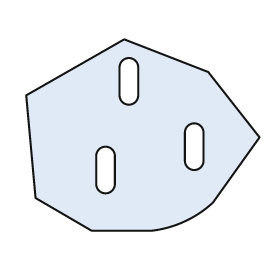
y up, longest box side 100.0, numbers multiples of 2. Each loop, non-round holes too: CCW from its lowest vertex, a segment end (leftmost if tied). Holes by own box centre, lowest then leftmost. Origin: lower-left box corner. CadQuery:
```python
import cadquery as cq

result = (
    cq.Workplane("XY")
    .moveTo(28.0, 0.0)
    .lineTo(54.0, 0.0)
    .threePointArc((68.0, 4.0), (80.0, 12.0))
    .lineTo(100.0, 40.0)
    .lineTo(78.0, 68.0)
    .lineTo(42.0, 82.0)
    .lineTo(0.0, 58.0)
    .lineTo(4.0, 14.0)
    .close()
    .moveTo(30.0, 20.0)
    .threePointArc((34.0, 16.0), (38.0, 20.0))
    .lineTo(38.0, 32.0)
    .threePointArc((34.0, 36.0), (30.0, 32.0))
    .close()
    .moveTo(68.0, 30.0)
    .threePointArc((72.0, 26.0), (76.0, 30.0))
    .lineTo(76.0, 42.0)
    .threePointArc((72.0, 46.0), (68.0, 42.0))
    .close()
    .moveTo(40.0, 58.0)
    .threePointArc((44.0, 54.0), (48.0, 58.0))
    .lineTo(48.0, 70.0)
    .threePointArc((44.0, 74.0), (40.0, 70.0))
    .close()
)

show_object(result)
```